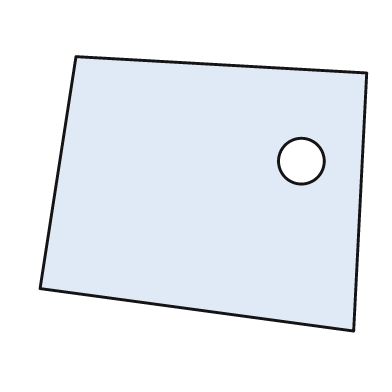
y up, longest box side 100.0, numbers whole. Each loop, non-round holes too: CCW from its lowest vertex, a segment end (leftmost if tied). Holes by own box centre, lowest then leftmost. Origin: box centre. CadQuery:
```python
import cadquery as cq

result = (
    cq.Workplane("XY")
    .moveTo(46.0, -42.0)
    .lineTo(50.0, 37.0)
    .lineTo(-39.0, 42.0)
    .lineTo(-50.0, -29.0)
    .close()
    .moveTo(30.0, 10.0)
    .circle(7.0)
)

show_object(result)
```